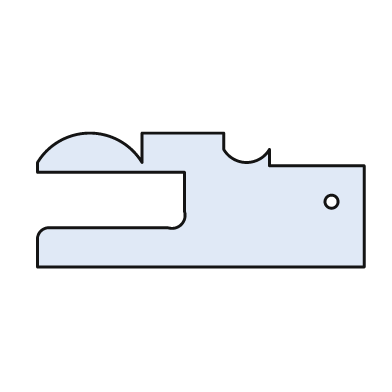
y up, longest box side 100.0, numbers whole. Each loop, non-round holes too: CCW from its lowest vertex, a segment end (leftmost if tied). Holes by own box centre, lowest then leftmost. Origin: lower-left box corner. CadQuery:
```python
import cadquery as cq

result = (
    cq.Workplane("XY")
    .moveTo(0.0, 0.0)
    .lineTo(100.0, 0.0)
    .lineTo(100.0, 31.0)
    .lineTo(71.0, 31.0)
    .lineTo(71.0, 36.0)
    .threePointArc((64.0, 32.0), (57.0, 36.0))
    .lineTo(57.0, 41.0)
    .lineTo(32.0, 41.0)
    .lineTo(32.0, 32.0)
    .threePointArc((16.0, 41.0), (0.0, 32.0))
    .lineTo(0.0, 29.0)
    .lineTo(45.0, 29.0)
    .lineTo(45.0, 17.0)
    .threePointArc((44.0, 13.0), (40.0, 12.0))
    .lineTo(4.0, 12.0)
    .threePointArc((1.0, 11.0), (0.0, 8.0))
    .close()
    .moveTo(90.0, 20.0)
    .circle(2.0)
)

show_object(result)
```